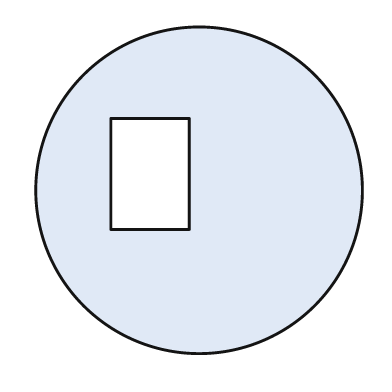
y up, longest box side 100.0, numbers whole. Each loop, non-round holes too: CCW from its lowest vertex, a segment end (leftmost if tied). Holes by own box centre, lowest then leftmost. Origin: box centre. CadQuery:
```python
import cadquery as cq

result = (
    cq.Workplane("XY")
    .moveTo(0.0, 0.0)
    .circle(50.0)
    .moveTo(-27.0, -12.0)
    .lineTo(-3.0, -12.0)
    .lineTo(-3.0, 22.0)
    .lineTo(-27.0, 22.0)
    .close()
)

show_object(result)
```